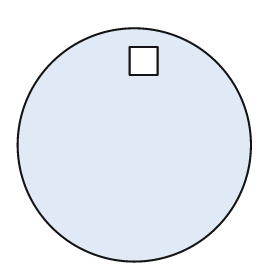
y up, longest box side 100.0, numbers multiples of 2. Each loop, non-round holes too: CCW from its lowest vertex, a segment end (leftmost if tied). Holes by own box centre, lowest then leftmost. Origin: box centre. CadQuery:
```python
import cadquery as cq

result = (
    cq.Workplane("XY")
    .moveTo(0.0, 0.0)
    .circle(50.0)
    .moveTo(-2.0, 30.0)
    .lineTo(10.0, 30.0)
    .lineTo(10.0, 42.0)
    .lineTo(-2.0, 42.0)
    .close()
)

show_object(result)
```